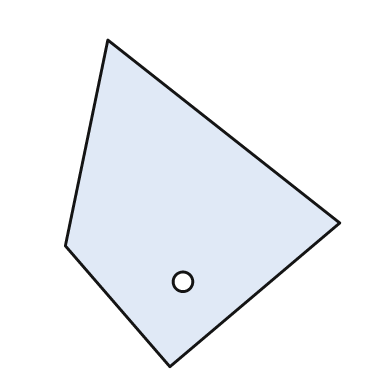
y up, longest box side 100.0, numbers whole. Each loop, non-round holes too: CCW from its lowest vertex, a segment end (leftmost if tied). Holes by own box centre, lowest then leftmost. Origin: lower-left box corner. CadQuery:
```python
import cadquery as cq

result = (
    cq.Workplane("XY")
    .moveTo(32.0, 0.0)
    .lineTo(84.0, 44.0)
    .lineTo(13.0, 100.0)
    .lineTo(0.0, 37.0)
    .close()
    .moveTo(36.0, 26.0)
    .circle(3.0)
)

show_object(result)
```